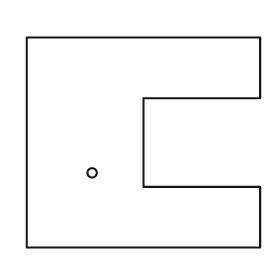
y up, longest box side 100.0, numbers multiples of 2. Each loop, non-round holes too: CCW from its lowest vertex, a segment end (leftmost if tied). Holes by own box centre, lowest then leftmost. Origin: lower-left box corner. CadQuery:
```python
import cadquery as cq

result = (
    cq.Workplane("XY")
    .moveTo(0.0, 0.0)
    .lineTo(100.0, 0.0)
    .lineTo(100.0, 26.0)
    .lineTo(50.0, 26.0)
    .lineTo(50.0, 64.0)
    .lineTo(100.0, 64.0)
    .lineTo(100.0, 90.0)
    .lineTo(0.0, 90.0)
    .close()
    .moveTo(28.0, 32.0)
    .circle(2.0)
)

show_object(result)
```